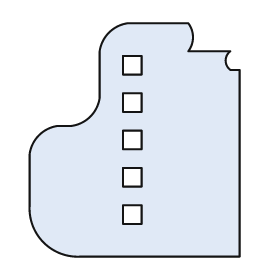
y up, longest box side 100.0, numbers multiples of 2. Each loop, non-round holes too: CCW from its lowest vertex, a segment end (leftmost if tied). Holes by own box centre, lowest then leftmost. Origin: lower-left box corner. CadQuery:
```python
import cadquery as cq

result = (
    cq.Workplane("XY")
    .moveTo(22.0, 0.0)
    .lineTo(90.0, 0.0)
    .lineTo(90.0, 80.0)
    .lineTo(86.0, 80.0)
    .threePointArc((84.0, 84.0), (86.0, 88.0))
    .lineTo(68.0, 88.0)
    .threePointArc((70.0, 94.0), (68.0, 100.0))
    .lineTo(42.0, 100.0)
    .threePointArc((34.0, 96.0), (30.0, 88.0))
    .lineTo(30.0, 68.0)
    .threePointArc((26.0, 60.0), (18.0, 56.0))
    .lineTo(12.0, 56.0)
    .threePointArc((4.0, 52.0), (0.0, 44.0))
    .lineTo(0.0, 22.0)
    .threePointArc((6.0, 6.0), (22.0, 0.0))
    .close()
    .moveTo(40.0, 14.0)
    .lineTo(48.0, 14.0)
    .lineTo(48.0, 22.0)
    .lineTo(40.0, 22.0)
    .close()
    .moveTo(40.0, 30.0)
    .lineTo(48.0, 30.0)
    .lineTo(48.0, 38.0)
    .lineTo(40.0, 38.0)
    .close()
    .moveTo(40.0, 46.0)
    .lineTo(48.0, 46.0)
    .lineTo(48.0, 54.0)
    .lineTo(40.0, 54.0)
    .close()
    .moveTo(40.0, 62.0)
    .lineTo(48.0, 62.0)
    .lineTo(48.0, 70.0)
    .lineTo(40.0, 70.0)
    .close()
    .moveTo(40.0, 78.0)
    .lineTo(48.0, 78.0)
    .lineTo(48.0, 86.0)
    .lineTo(40.0, 86.0)
    .close()
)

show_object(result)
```